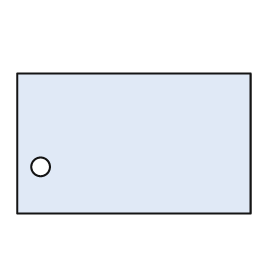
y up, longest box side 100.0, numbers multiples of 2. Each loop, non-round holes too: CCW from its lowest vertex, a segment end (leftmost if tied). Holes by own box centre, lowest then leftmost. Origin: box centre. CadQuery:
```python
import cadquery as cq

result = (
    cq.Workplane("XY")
    .moveTo(-50.0, -30.0)
    .lineTo(50.0, -30.0)
    .lineTo(50.0, 30.0)
    .lineTo(-50.0, 30.0)
    .close()
    .moveTo(-40.0, -10.0)
    .circle(4.0)
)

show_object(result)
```